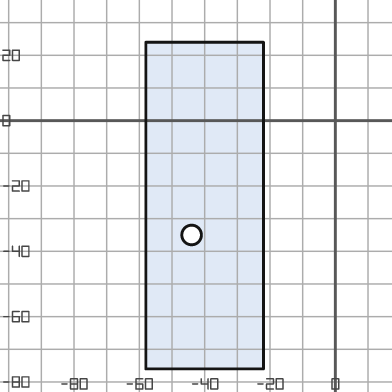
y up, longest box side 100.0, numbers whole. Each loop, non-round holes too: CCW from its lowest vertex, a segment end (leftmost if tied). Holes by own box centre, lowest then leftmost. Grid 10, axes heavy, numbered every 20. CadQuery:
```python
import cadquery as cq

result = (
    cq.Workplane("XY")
    .moveTo(-58.0, -76.0)
    .lineTo(-22.0, -76.0)
    .lineTo(-22.0, 24.0)
    .lineTo(-58.0, 24.0)
    .close()
    .moveTo(-44.0, -35.0)
    .circle(3.0)
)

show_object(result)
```